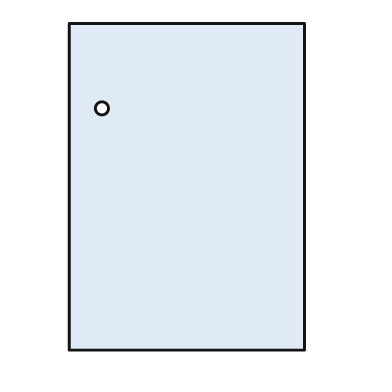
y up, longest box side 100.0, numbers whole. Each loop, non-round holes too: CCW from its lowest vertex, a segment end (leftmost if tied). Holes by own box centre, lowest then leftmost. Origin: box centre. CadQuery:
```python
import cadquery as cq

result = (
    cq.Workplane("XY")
    .moveTo(-36.0, -50.0)
    .lineTo(36.0, -50.0)
    .lineTo(36.0, 50.0)
    .lineTo(-36.0, 50.0)
    .close()
    .moveTo(-26.0, 24.0)
    .circle(2.0)
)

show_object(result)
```